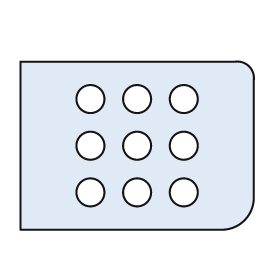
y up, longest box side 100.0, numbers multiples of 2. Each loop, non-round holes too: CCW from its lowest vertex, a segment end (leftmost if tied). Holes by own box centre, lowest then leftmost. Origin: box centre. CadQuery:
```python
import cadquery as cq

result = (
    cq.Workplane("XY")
    .moveTo(-50.0, -36.0)
    .lineTo(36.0, -36.0)
    .threePointArc((46.0, -32.0), (50.0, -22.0))
    .lineTo(50.0, 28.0)
    .threePointArc((48.0, 34.0), (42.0, 36.0))
    .lineTo(-50.0, 36.0)
    .close()
    .moveTo(-20.0, -20.0)
    .circle(6.0)
    .moveTo(0.0, -20.0)
    .circle(6.0)
    .moveTo(20.0, -20.0)
    .circle(6.0)
    .moveTo(-20.0, 0.0)
    .circle(6.0)
    .moveTo(0.0, 0.0)
    .circle(6.0)
    .moveTo(20.0, 0.0)
    .circle(6.0)
    .moveTo(-20.0, 20.0)
    .circle(6.0)
    .moveTo(0.0, 20.0)
    .circle(6.0)
    .moveTo(20.0, 20.0)
    .circle(6.0)
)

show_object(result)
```